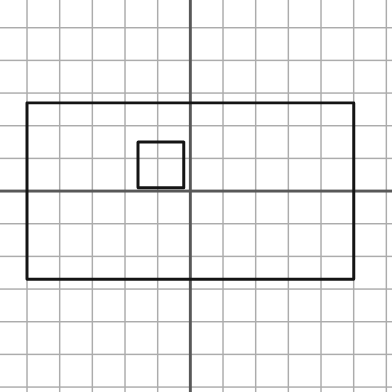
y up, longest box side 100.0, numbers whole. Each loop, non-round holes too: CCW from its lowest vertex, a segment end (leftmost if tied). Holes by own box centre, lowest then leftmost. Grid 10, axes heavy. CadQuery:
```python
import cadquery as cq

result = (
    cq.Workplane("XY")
    .moveTo(-50.0, -27.0)
    .lineTo(50.0, -27.0)
    .lineTo(50.0, 27.0)
    .lineTo(-50.0, 27.0)
    .close()
    .moveTo(-16.0, 1.0)
    .lineTo(-2.0, 1.0)
    .lineTo(-2.0, 15.0)
    .lineTo(-16.0, 15.0)
    .close()
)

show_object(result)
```